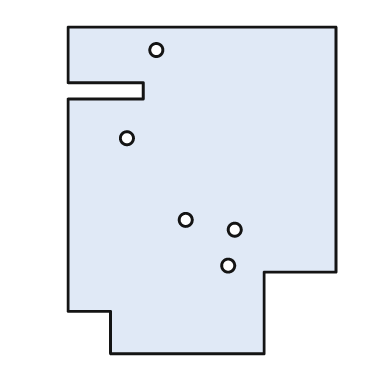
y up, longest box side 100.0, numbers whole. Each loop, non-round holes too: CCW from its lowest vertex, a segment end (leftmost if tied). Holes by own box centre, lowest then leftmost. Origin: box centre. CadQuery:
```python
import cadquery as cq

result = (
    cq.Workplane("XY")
    .moveTo(-28.0, -50.0)
    .lineTo(19.0, -50.0)
    .lineTo(19.0, -25.0)
    .lineTo(41.0, -25.0)
    .lineTo(41.0, 50.0)
    .lineTo(-41.0, 50.0)
    .lineTo(-41.0, 33.0)
    .lineTo(-18.0, 33.0)
    .lineTo(-18.0, 28.0)
    .lineTo(-41.0, 28.0)
    .lineTo(-41.0, -37.0)
    .lineTo(-28.0, -37.0)
    .close()
    .moveTo(8.0, -23.0)
    .circle(2.0)
    .moveTo(10.0, -12.0)
    .circle(2.0)
    .moveTo(-5.0, -9.0)
    .circle(2.0)
    .moveTo(-23.0, 16.0)
    .circle(2.0)
    .moveTo(-14.0, 43.0)
    .circle(2.0)
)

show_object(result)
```